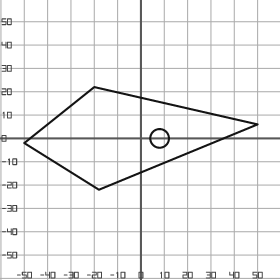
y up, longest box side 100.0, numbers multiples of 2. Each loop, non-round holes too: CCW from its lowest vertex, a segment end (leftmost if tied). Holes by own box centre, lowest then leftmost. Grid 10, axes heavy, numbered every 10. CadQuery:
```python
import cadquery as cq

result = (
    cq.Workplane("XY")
    .moveTo(-18.0, -22.0)
    .lineTo(50.0, 6.0)
    .lineTo(-20.0, 22.0)
    .lineTo(-50.0, -2.0)
    .close()
    .moveTo(8.0, 0.0)
    .circle(4.0)
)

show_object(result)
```